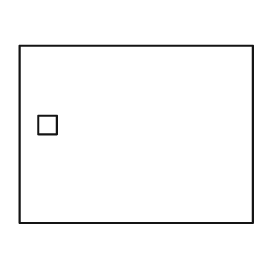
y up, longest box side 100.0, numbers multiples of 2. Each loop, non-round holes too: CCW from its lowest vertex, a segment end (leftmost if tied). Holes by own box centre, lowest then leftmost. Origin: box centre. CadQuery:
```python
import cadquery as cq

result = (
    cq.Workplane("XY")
    .moveTo(-50.0, -38.0)
    .lineTo(50.0, -38.0)
    .lineTo(50.0, 38.0)
    .lineTo(-50.0, 38.0)
    .close()
    .moveTo(-42.0, 0.0)
    .lineTo(-34.0, 0.0)
    .lineTo(-34.0, 8.0)
    .lineTo(-42.0, 8.0)
    .close()
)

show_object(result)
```